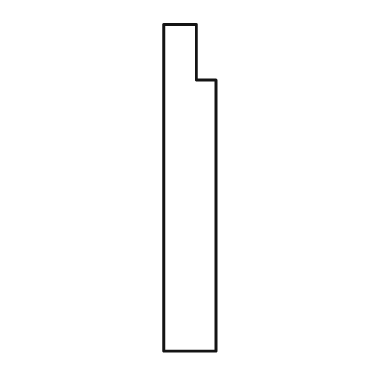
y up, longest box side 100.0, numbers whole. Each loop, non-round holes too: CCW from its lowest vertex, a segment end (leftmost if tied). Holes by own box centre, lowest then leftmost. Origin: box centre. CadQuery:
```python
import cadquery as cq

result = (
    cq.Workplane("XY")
    .moveTo(-8.0, -50.0)
    .lineTo(8.0, -50.0)
    .lineTo(8.0, 33.0)
    .lineTo(2.0, 33.0)
    .lineTo(2.0, 50.0)
    .lineTo(-8.0, 50.0)
    .close()
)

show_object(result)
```